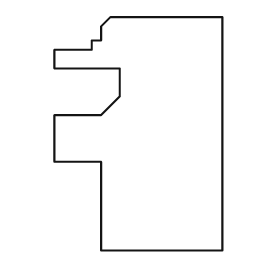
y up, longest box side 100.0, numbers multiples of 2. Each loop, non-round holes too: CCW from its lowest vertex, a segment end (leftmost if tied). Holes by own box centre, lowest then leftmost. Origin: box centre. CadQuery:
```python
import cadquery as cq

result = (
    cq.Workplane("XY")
    .moveTo(-16.0, -50.0)
    .lineTo(36.0, -50.0)
    .lineTo(36.0, 50.0)
    .lineTo(-12.0, 50.0)
    .lineTo(-16.0, 46.0)
    .lineTo(-16.0, 40.0)
    .lineTo(-20.0, 40.0)
    .lineTo(-20.0, 36.0)
    .lineTo(-36.0, 36.0)
    .lineTo(-36.0, 28.0)
    .lineTo(-8.0, 28.0)
    .lineTo(-8.0, 16.0)
    .lineTo(-16.0, 8.0)
    .lineTo(-36.0, 8.0)
    .lineTo(-36.0, -12.0)
    .lineTo(-16.0, -12.0)
    .close()
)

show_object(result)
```